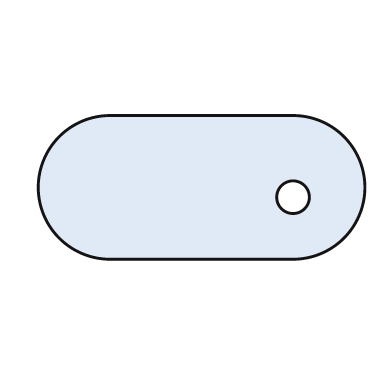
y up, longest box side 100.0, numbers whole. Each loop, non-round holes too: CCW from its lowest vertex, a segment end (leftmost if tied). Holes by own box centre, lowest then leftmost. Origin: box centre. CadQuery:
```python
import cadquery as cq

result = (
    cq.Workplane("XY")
    .moveTo(-28.0, -22.0)
    .lineTo(28.0, -22.0)
    .threePointArc((50.0, 0.0), (28.0, 22.0))
    .lineTo(-28.0, 22.0)
    .threePointArc((-50.0, 0.0), (-28.0, -22.0))
    .close()
    .moveTo(28.0, -3.0)
    .circle(5.0)
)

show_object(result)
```